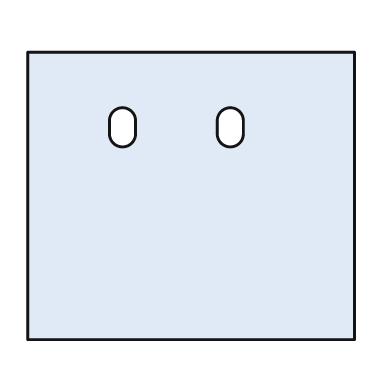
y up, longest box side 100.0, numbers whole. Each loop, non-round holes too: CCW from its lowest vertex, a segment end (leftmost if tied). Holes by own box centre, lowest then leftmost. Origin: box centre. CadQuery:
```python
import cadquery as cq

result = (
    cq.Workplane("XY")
    .moveTo(-50.0, -44.0)
    .lineTo(50.0, -44.0)
    .lineTo(50.0, 44.0)
    .lineTo(-50.0, 44.0)
    .close()
    .moveTo(-25.0, 19.0)
    .threePointArc((-21.0, 15.0), (-17.0, 19.0))
    .lineTo(-17.0, 23.0)
    .threePointArc((-21.0, 27.0), (-25.0, 23.0))
    .close()
    .moveTo(8.0, 19.0)
    .threePointArc((12.0, 15.0), (16.0, 19.0))
    .lineTo(16.0, 23.0)
    .threePointArc((12.0, 27.0), (8.0, 23.0))
    .close()
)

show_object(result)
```